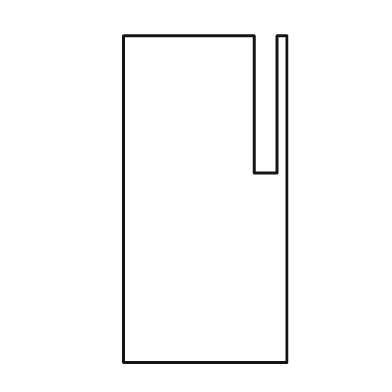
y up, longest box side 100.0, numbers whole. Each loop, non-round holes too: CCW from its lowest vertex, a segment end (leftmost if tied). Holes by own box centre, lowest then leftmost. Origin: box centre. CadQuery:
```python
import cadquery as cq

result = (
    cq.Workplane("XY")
    .moveTo(-25.0, -50.0)
    .lineTo(25.0, -50.0)
    .lineTo(25.0, 50.0)
    .lineTo(22.0, 50.0)
    .lineTo(22.0, 8.0)
    .lineTo(15.0, 8.0)
    .lineTo(15.0, 50.0)
    .lineTo(-25.0, 50.0)
    .close()
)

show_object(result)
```